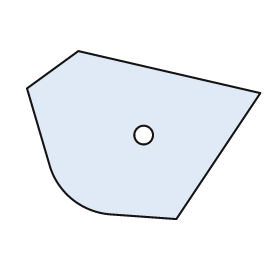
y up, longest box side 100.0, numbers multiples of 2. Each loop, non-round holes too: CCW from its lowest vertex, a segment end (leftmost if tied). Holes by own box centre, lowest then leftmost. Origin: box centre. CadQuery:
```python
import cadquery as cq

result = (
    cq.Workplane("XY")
    .moveTo(14.0, -36.0)
    .lineTo(50.0, 18.0)
    .lineTo(-28.0, 36.0)
    .lineTo(-50.0, 20.0)
    .lineTo(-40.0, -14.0)
    .threePointArc((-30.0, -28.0), (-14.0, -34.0))
    .close()
    .moveTo(0.0, 0.0)
    .circle(4.0)
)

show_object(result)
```